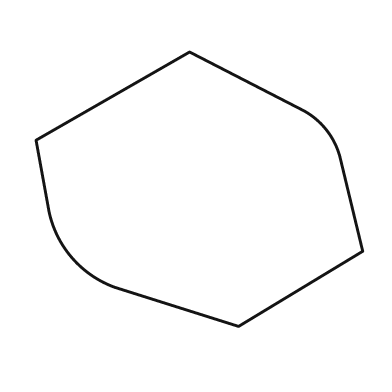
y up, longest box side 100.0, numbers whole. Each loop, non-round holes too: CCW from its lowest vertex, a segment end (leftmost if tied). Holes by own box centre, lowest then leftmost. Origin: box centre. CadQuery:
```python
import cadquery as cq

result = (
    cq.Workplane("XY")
    .moveTo(12.0, -42.0)
    .lineTo(50.0, -19.0)
    .lineTo(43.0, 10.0)
    .threePointArc((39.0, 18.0), (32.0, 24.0))
    .lineTo(-3.0, 42.0)
    .lineTo(-50.0, 15.0)
    .lineTo(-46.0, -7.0)
    .threePointArc((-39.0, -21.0), (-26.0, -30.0))
    .close()
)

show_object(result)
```